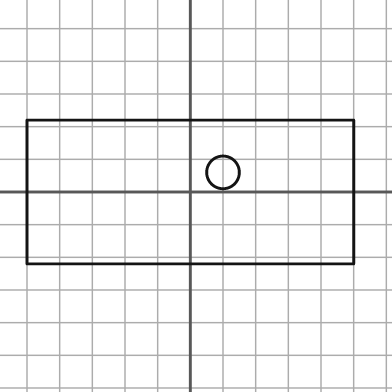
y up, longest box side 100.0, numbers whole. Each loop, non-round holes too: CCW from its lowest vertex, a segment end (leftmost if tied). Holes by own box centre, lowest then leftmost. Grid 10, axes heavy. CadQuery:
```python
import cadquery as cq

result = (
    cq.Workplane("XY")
    .moveTo(-50.0, -22.0)
    .lineTo(50.0, -22.0)
    .lineTo(50.0, 22.0)
    .lineTo(-50.0, 22.0)
    .close()
    .moveTo(10.0, 6.0)
    .circle(5.0)
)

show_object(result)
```